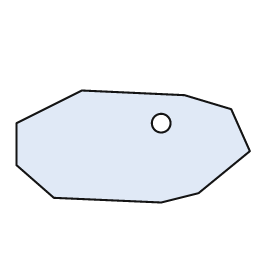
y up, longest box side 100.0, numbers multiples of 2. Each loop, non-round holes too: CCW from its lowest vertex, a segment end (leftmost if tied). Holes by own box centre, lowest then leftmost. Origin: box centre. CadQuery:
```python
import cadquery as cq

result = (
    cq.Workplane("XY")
    .moveTo(12.0, -24.0)
    .lineTo(28.0, -20.0)
    .lineTo(50.0, -2.0)
    .lineTo(42.0, 16.0)
    .lineTo(22.0, 22.0)
    .lineTo(-22.0, 24.0)
    .lineTo(-50.0, 10.0)
    .lineTo(-50.0, -8.0)
    .lineTo(-34.0, -22.0)
    .close()
    .moveTo(12.0, 10.0)
    .circle(4.0)
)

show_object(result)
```